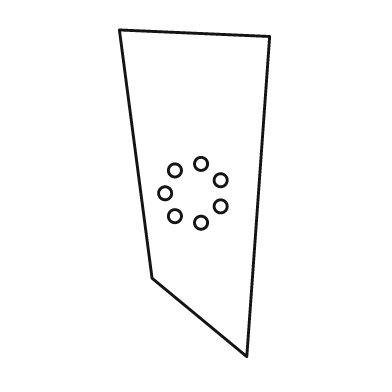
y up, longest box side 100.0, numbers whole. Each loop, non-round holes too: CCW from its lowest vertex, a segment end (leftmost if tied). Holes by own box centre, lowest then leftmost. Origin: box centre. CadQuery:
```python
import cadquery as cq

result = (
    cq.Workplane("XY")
    .moveTo(16.0, -50.0)
    .lineTo(23.0, 48.0)
    .lineTo(-23.0, 50.0)
    .lineTo(-13.0, -26.0)
    .close()
    .moveTo(2.0, -9.0)
    .circle(2.0)
    .moveTo(-6.0, -7.0)
    .circle(2.0)
    .moveTo(8.0, -4.0)
    .circle(2.0)
    .moveTo(-9.0, 0.0)
    .circle(2.0)
    .moveTo(8.0, 4.0)
    .circle(2.0)
    .moveTo(-6.0, 7.0)
    .circle(2.0)
    .moveTo(2.0, 9.0)
    .circle(2.0)
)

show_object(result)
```